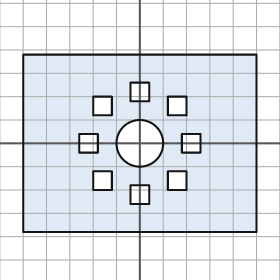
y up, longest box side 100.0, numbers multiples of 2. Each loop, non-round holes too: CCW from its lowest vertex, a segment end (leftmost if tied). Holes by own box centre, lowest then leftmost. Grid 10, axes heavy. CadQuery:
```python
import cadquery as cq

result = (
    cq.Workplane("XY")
    .moveTo(-50.0, -38.0)
    .lineTo(50.0, -38.0)
    .lineTo(50.0, 38.0)
    .lineTo(-50.0, 38.0)
    .close()
    .moveTo(-4.0, -26.0)
    .lineTo(4.0, -26.0)
    .lineTo(4.0, -18.0)
    .lineTo(-4.0, -18.0)
    .close()
    .moveTo(-20.0, -20.0)
    .lineTo(-12.0, -20.0)
    .lineTo(-12.0, -12.0)
    .lineTo(-20.0, -12.0)
    .close()
    .moveTo(12.0, -20.0)
    .lineTo(20.0, -20.0)
    .lineTo(20.0, -12.0)
    .lineTo(12.0, -12.0)
    .close()
    .moveTo(-26.0, -4.0)
    .lineTo(-18.0, -4.0)
    .lineTo(-18.0, 4.0)
    .lineTo(-26.0, 4.0)
    .close()
    .moveTo(0.0, 0.0)
    .circle(10.0)
    .moveTo(18.0, -4.0)
    .lineTo(26.0, -4.0)
    .lineTo(26.0, 4.0)
    .lineTo(18.0, 4.0)
    .close()
    .moveTo(-20.0, 12.0)
    .lineTo(-12.0, 12.0)
    .lineTo(-12.0, 20.0)
    .lineTo(-20.0, 20.0)
    .close()
    .moveTo(12.0, 12.0)
    .lineTo(20.0, 12.0)
    .lineTo(20.0, 20.0)
    .lineTo(12.0, 20.0)
    .close()
    .moveTo(-4.0, 18.0)
    .lineTo(4.0, 18.0)
    .lineTo(4.0, 26.0)
    .lineTo(-4.0, 26.0)
    .close()
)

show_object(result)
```